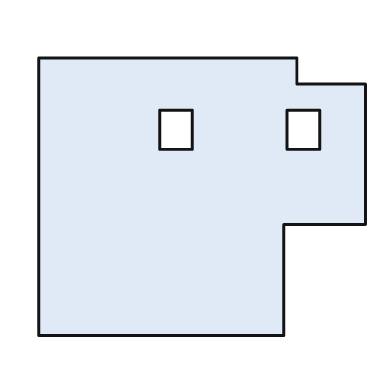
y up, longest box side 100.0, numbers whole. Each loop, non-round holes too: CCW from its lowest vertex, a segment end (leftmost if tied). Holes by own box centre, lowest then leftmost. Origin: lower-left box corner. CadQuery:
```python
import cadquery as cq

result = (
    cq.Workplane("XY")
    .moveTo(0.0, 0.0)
    .lineTo(75.0, 0.0)
    .lineTo(75.0, 34.0)
    .lineTo(100.0, 34.0)
    .lineTo(100.0, 77.0)
    .lineTo(79.0, 77.0)
    .lineTo(79.0, 85.0)
    .lineTo(0.0, 85.0)
    .close()
    .moveTo(37.0, 57.0)
    .lineTo(47.0, 57.0)
    .lineTo(47.0, 69.0)
    .lineTo(37.0, 69.0)
    .close()
    .moveTo(76.0, 57.0)
    .lineTo(86.0, 57.0)
    .lineTo(86.0, 69.0)
    .lineTo(76.0, 69.0)
    .close()
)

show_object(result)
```